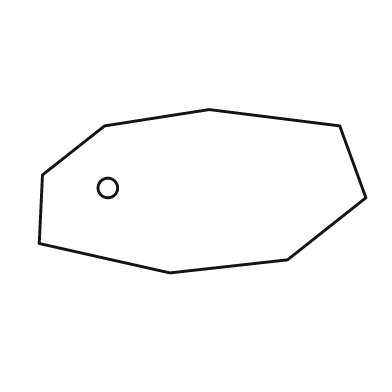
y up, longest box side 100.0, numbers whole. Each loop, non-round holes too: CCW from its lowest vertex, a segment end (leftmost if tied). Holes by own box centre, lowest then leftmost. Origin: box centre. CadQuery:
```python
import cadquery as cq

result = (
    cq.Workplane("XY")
    .moveTo(-10.0, -25.0)
    .lineTo(26.0, -21.0)
    .lineTo(50.0, -2.0)
    .lineTo(42.0, 20.0)
    .lineTo(2.0, 25.0)
    .lineTo(-30.0, 20.0)
    .lineTo(-49.0, 5.0)
    .lineTo(-50.0, -16.0)
    .close()
    .moveTo(-29.0, 1.0)
    .circle(3.0)
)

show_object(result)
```